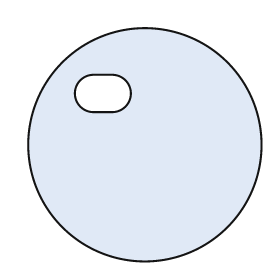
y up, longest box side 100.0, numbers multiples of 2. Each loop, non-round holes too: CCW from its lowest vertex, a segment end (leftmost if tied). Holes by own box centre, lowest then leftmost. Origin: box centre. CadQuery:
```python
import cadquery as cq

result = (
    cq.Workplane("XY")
    .moveTo(0.0, 0.0)
    .circle(50.0)
    .moveTo(-22.0, 14.0)
    .lineTo(-14.0, 14.0)
    .threePointArc((-6.0, 22.0), (-14.0, 30.0))
    .lineTo(-22.0, 30.0)
    .threePointArc((-30.0, 22.0), (-22.0, 14.0))
    .close()
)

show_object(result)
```